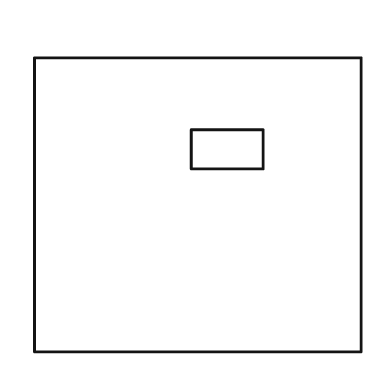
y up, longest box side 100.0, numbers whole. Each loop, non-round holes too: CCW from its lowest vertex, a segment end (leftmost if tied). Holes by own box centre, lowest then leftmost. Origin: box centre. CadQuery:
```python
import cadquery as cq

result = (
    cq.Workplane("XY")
    .moveTo(-50.0, -45.0)
    .lineTo(50.0, -45.0)
    .lineTo(50.0, 45.0)
    .lineTo(-50.0, 45.0)
    .close()
    .moveTo(-2.0, 11.0)
    .lineTo(20.0, 11.0)
    .lineTo(20.0, 23.0)
    .lineTo(-2.0, 23.0)
    .close()
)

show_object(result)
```